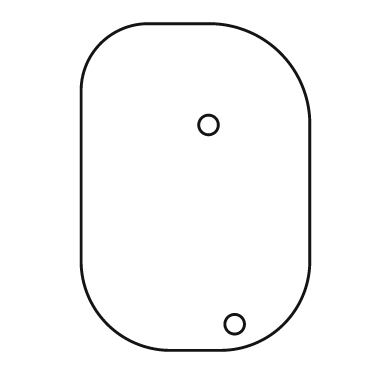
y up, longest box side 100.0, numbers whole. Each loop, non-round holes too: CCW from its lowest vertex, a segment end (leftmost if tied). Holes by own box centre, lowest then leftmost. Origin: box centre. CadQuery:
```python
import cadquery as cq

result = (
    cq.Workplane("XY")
    .moveTo(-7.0, -50.0)
    .lineTo(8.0, -50.0)
    .threePointArc((27.0, -42.0), (35.0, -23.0))
    .lineTo(35.0, 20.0)
    .threePointArc((26.0, 41.0), (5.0, 50.0))
    .lineTo(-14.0, 50.0)
    .threePointArc((-29.0, 44.0), (-35.0, 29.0))
    .lineTo(-35.0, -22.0)
    .threePointArc((-27.0, -42.0), (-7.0, -50.0))
    .close()
    .moveTo(12.0, -42.0)
    .circle(3.0)
    .moveTo(4.0, 19.0)
    .circle(3.0)
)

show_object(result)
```